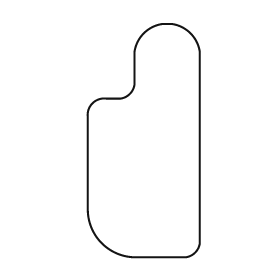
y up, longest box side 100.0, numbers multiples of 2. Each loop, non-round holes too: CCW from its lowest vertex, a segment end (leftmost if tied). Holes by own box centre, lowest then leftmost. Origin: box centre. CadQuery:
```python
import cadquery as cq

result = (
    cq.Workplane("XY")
    .moveTo(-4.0, -50.0)
    .lineTo(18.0, -50.0)
    .threePointArc((22.0, -48.0), (24.0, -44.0))
    .lineTo(24.0, 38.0)
    .threePointArc((20.0, 46.0), (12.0, 50.0))
    .lineTo(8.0, 50.0)
    .threePointArc((0.0, 46.0), (-4.0, 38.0))
    .lineTo(-4.0, 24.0)
    .threePointArc((-6.0, 20.0), (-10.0, 18.0))
    .lineTo(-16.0, 18.0)
    .threePointArc((-22.0, 16.0), (-24.0, 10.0))
    .lineTo(-24.0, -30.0)
    .threePointArc((-18.0, -44.0), (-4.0, -50.0))
    .close()
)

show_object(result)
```